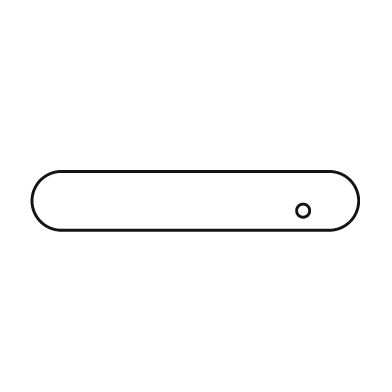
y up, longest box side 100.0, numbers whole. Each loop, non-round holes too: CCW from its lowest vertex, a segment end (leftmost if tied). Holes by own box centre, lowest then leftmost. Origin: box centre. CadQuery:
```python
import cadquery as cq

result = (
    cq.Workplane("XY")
    .moveTo(-41.0, -9.0)
    .lineTo(41.0, -9.0)
    .threePointArc((50.0, 0.0), (41.0, 9.0))
    .lineTo(-41.0, 9.0)
    .threePointArc((-50.0, 0.0), (-41.0, -9.0))
    .close()
    .moveTo(33.0, -3.0)
    .circle(2.0)
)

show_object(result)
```